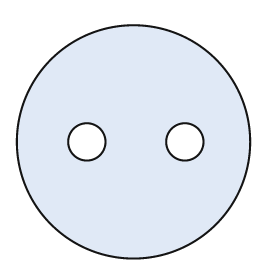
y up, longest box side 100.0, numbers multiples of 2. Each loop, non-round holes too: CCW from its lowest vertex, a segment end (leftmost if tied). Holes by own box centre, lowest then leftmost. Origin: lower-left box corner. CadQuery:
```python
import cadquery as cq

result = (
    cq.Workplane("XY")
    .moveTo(50.0, 50.0)
    .circle(50.0)
    .moveTo(30.0, 50.0)
    .circle(8.0)
    .moveTo(72.0, 50.0)
    .circle(8.0)
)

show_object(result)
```